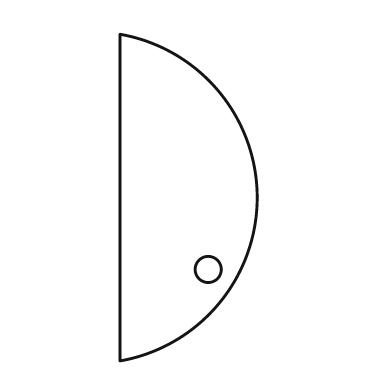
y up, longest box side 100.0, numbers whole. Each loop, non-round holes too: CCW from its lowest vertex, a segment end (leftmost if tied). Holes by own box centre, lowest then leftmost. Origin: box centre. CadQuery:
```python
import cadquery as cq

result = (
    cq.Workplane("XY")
    .moveTo(-21.0, -50.0)
    .threePointArc((21.0, 0.0), (-21.0, 50.0))
    .close()
    .moveTo(6.0, -22.0)
    .circle(4.0)
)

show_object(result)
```